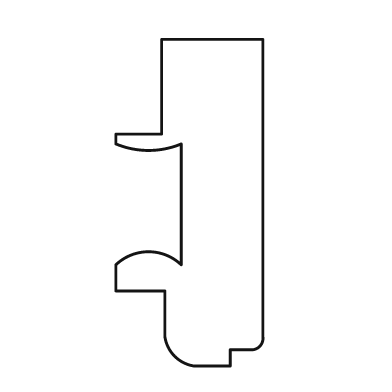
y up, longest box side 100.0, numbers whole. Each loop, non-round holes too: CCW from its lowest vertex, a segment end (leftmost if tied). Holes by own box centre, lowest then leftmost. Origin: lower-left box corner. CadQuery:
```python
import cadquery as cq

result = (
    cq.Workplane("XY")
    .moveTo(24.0, 0.0)
    .lineTo(35.0, 0.0)
    .lineTo(35.0, 5.0)
    .lineTo(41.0, 5.0)
    .threePointArc((44.0, 6.0), (45.0, 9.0))
    .lineTo(45.0, 100.0)
    .lineTo(14.0, 100.0)
    .lineTo(14.0, 71.0)
    .lineTo(0.0, 71.0)
    .lineTo(0.0, 68.0)
    .threePointArc((10.0, 66.0), (20.0, 68.0))
    .lineTo(20.0, 31.0)
    .threePointArc((10.0, 35.0), (0.0, 31.0))
    .lineTo(0.0, 23.0)
    .lineTo(15.0, 23.0)
    .lineTo(15.0, 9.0)
    .threePointArc((18.0, 3.0), (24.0, 0.0))
    .close()
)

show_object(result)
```